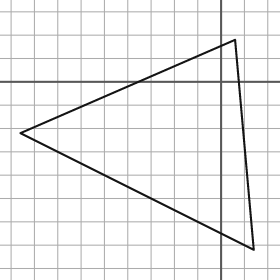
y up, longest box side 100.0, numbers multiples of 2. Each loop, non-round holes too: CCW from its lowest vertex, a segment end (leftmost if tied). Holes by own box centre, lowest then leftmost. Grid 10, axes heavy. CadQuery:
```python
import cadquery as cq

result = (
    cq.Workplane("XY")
    .moveTo(14.0, -72.0)
    .lineTo(6.0, 18.0)
    .lineTo(-86.0, -22.0)
    .close()
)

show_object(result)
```